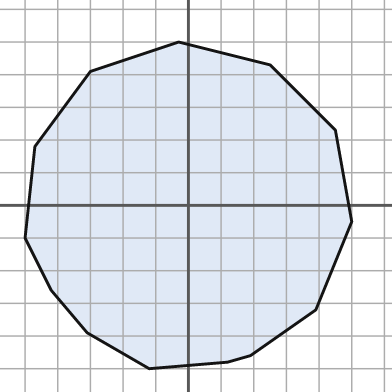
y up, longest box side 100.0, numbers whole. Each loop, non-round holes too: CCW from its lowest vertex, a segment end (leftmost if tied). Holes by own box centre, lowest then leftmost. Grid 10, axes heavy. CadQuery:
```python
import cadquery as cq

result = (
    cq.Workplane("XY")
    .moveTo(-12.0, -50.0)
    .lineTo(12.0, -48.0)
    .lineTo(19.0, -46.0)
    .lineTo(39.0, -32.0)
    .lineTo(50.0, -5.0)
    .lineTo(45.0, 23.0)
    .lineTo(25.0, 43.0)
    .lineTo(-3.0, 50.0)
    .lineTo(-30.0, 41.0)
    .lineTo(-47.0, 18.0)
    .lineTo(-50.0, -10.0)
    .lineTo(-42.0, -26.0)
    .lineTo(-31.0, -39.0)
    .close()
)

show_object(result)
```